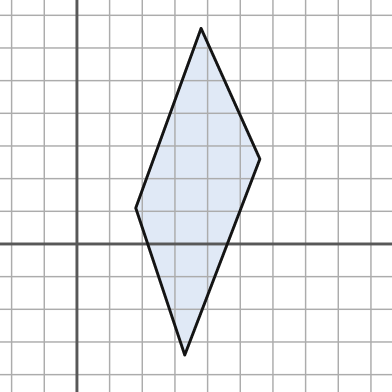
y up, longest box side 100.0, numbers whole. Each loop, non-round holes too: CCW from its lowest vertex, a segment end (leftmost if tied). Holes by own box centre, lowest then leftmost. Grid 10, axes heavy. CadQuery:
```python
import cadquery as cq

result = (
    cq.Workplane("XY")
    .moveTo(33.0, -34.0)
    .lineTo(56.0, 26.0)
    .lineTo(38.0, 66.0)
    .lineTo(18.0, 11.0)
    .close()
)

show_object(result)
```